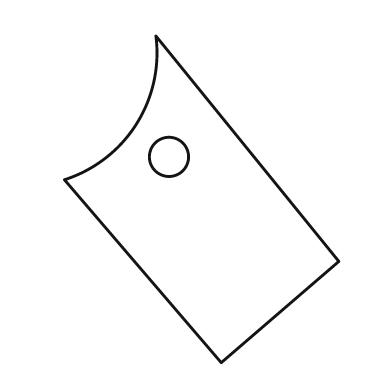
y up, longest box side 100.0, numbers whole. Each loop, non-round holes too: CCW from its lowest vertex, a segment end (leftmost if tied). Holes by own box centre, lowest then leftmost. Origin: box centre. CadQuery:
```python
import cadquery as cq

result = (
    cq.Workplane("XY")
    .moveTo(6.0, -50.0)
    .lineTo(42.0, -19.0)
    .lineTo(-14.0, 50.0)
    .threePointArc((-20.0, 23.0), (-42.0, 6.0))
    .close()
    .moveTo(-10.0, 13.0)
    .circle(6.0)
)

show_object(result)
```